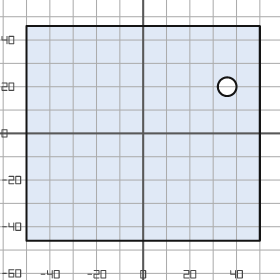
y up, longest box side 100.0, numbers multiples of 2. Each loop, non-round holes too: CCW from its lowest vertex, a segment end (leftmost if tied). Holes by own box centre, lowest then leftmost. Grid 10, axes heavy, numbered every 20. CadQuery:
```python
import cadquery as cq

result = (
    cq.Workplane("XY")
    .moveTo(-50.0, -46.0)
    .lineTo(50.0, -46.0)
    .lineTo(50.0, 46.0)
    .lineTo(-50.0, 46.0)
    .close()
    .moveTo(36.0, 20.0)
    .circle(4.0)
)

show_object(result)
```